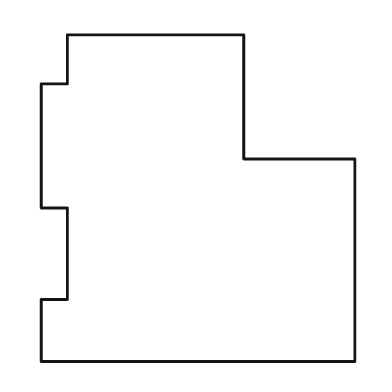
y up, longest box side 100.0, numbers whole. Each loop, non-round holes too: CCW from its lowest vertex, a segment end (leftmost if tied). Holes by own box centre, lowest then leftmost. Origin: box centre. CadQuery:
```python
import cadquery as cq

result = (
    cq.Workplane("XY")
    .moveTo(-48.0, -50.0)
    .lineTo(48.0, -50.0)
    .lineTo(48.0, 12.0)
    .lineTo(14.0, 12.0)
    .lineTo(14.0, 50.0)
    .lineTo(-40.0, 50.0)
    .lineTo(-40.0, 35.0)
    .lineTo(-48.0, 35.0)
    .lineTo(-48.0, -3.0)
    .lineTo(-40.0, -3.0)
    .lineTo(-40.0, -31.0)
    .lineTo(-48.0, -31.0)
    .close()
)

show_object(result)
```